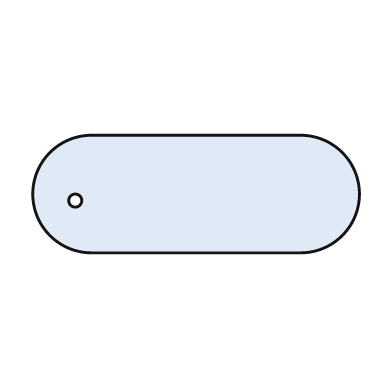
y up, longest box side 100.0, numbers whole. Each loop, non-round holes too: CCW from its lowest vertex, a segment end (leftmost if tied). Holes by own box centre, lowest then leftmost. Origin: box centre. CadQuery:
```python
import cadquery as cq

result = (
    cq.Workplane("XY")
    .moveTo(-32.0, -18.0)
    .lineTo(32.0, -18.0)
    .threePointArc((50.0, 0.0), (32.0, 18.0))
    .lineTo(-32.0, 18.0)
    .threePointArc((-50.0, 0.0), (-32.0, -18.0))
    .close()
    .moveTo(-37.0, -2.0)
    .circle(2.0)
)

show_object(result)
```